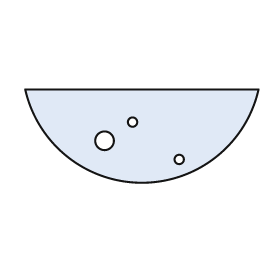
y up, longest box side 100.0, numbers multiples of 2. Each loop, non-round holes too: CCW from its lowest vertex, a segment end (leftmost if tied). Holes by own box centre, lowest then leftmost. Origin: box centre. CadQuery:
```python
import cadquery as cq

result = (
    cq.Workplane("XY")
    .moveTo(-50.0, 20.0)
    .threePointArc((0.0, -20.0), (50.0, 20.0))
    .close()
    .moveTo(16.0, -10.0)
    .circle(2.0)
    .moveTo(-16.0, -2.0)
    .circle(4.0)
    .moveTo(-4.0, 6.0)
    .circle(2.0)
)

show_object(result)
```